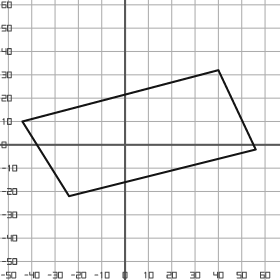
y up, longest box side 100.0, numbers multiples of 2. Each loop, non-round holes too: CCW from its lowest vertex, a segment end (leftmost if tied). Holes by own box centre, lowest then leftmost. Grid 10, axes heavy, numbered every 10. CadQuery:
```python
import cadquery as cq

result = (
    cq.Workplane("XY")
    .moveTo(-24.0, -22.0)
    .lineTo(56.0, -2.0)
    .lineTo(40.0, 32.0)
    .lineTo(-44.0, 10.0)
    .close()
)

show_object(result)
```